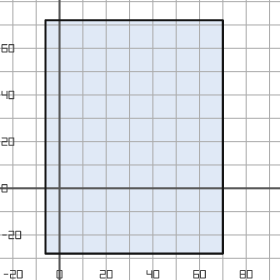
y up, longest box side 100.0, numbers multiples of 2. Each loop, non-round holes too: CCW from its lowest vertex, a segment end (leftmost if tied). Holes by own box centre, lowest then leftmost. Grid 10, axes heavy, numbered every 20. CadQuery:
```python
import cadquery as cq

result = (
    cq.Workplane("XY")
    .moveTo(-6.0, -28.0)
    .lineTo(70.0, -28.0)
    .lineTo(70.0, 72.0)
    .lineTo(-6.0, 72.0)
    .close()
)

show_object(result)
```